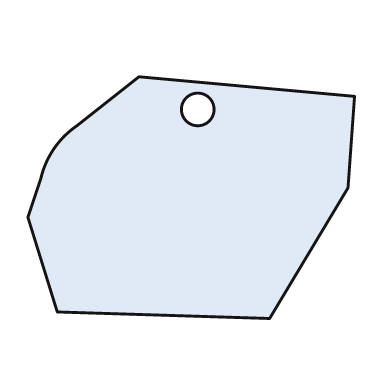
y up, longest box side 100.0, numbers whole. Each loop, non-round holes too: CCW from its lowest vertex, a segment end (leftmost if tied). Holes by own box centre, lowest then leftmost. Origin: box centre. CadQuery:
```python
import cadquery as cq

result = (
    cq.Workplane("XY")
    .moveTo(24.0, -37.0)
    .lineTo(48.0, 3.0)
    .lineTo(50.0, 31.0)
    .lineTo(-16.0, 37.0)
    .lineTo(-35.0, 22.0)
    .threePointArc((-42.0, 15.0), (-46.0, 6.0))
    .lineTo(-50.0, -6.0)
    .lineTo(-41.0, -35.0)
    .close()
    .moveTo(2.0, 27.0)
    .circle(5.0)
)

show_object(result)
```